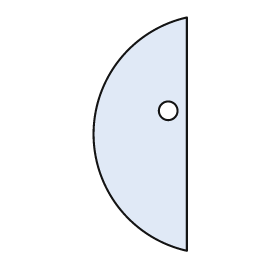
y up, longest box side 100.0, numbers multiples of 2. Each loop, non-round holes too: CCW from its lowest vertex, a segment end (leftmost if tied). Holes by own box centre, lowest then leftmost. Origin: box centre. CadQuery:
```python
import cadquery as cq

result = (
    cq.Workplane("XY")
    .moveTo(20.0, -50.0)
    .lineTo(20.0, 50.0)
    .threePointArc((-20.0, 0.0), (20.0, -50.0))
    .close()
    .moveTo(12.0, 10.0)
    .circle(4.0)
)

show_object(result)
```